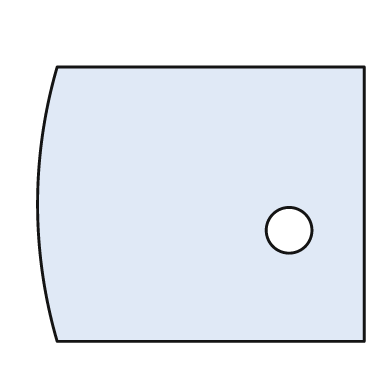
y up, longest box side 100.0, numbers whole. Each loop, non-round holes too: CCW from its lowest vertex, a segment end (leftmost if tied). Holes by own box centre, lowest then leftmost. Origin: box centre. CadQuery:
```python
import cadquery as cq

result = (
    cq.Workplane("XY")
    .moveTo(-44.0, -42.0)
    .lineTo(50.0, -42.0)
    .lineTo(50.0, 42.0)
    .lineTo(-44.0, 42.0)
    .threePointArc((-50.0, 0.0), (-44.0, -42.0))
    .close()
    .moveTo(27.0, -8.0)
    .circle(7.0)
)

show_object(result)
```